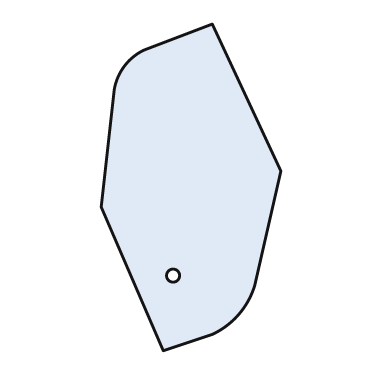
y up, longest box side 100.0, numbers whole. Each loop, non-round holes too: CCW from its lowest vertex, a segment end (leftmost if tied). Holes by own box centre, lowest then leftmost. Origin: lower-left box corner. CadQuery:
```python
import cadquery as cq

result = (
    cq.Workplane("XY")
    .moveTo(19.0, 0.0)
    .lineTo(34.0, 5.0)
    .threePointArc((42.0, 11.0), (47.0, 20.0))
    .lineTo(55.0, 55.0)
    .lineTo(34.0, 100.0)
    .lineTo(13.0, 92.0)
    .threePointArc((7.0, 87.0), (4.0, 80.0))
    .lineTo(0.0, 44.0)
    .close()
    .moveTo(22.0, 23.0)
    .circle(2.0)
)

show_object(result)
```